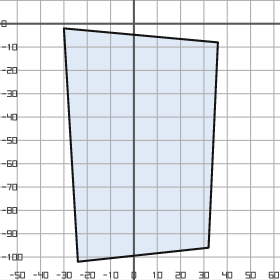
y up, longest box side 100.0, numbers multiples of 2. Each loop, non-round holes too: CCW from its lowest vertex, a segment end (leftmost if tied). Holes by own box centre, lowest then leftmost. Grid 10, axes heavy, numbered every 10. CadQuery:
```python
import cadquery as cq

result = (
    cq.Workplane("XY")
    .moveTo(-24.0, -102.0)
    .lineTo(32.0, -96.0)
    .lineTo(36.0, -8.0)
    .lineTo(-30.0, -2.0)
    .close()
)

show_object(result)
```